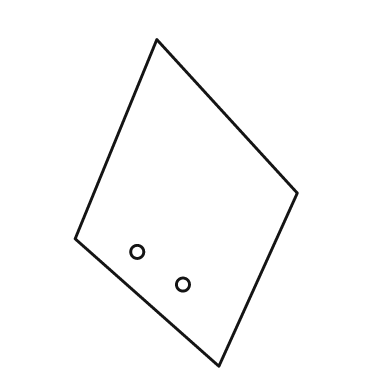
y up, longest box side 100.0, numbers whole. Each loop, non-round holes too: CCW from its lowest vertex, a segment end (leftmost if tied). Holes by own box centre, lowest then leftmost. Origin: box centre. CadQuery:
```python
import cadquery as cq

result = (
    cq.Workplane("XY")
    .moveTo(10.0, -50.0)
    .lineTo(34.0, 3.0)
    .lineTo(-9.0, 50.0)
    .lineTo(-34.0, -11.0)
    .close()
    .moveTo(-1.0, -25.0)
    .circle(2.0)
    .moveTo(-15.0, -15.0)
    .circle(2.0)
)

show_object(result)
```